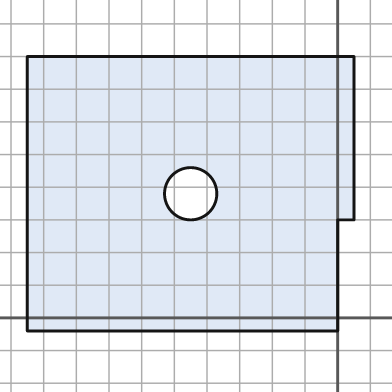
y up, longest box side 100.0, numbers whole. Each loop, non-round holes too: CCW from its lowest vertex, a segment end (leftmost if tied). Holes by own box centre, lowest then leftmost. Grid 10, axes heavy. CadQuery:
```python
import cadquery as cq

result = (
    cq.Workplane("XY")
    .moveTo(-95.0, -4.0)
    .lineTo(0.0, -4.0)
    .lineTo(0.0, 30.0)
    .lineTo(5.0, 30.0)
    .lineTo(5.0, 80.0)
    .lineTo(-95.0, 80.0)
    .close()
    .moveTo(-45.0, 38.0)
    .circle(8.0)
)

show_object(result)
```